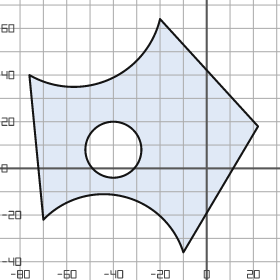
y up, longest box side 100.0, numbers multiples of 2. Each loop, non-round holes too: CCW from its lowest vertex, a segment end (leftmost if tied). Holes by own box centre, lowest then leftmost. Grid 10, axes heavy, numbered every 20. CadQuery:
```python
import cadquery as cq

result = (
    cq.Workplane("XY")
    .moveTo(-10.0, -36.0)
    .lineTo(22.0, 18.0)
    .lineTo(-20.0, 64.0)
    .threePointArc((-42.0, 38.0), (-76.0, 40.0))
    .lineTo(-70.0, -22.0)
    .threePointArc((-36.0, -12.0), (-10.0, -36.0))
    .close()
    .moveTo(-40.0, 8.0)
    .circle(12.0)
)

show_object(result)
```